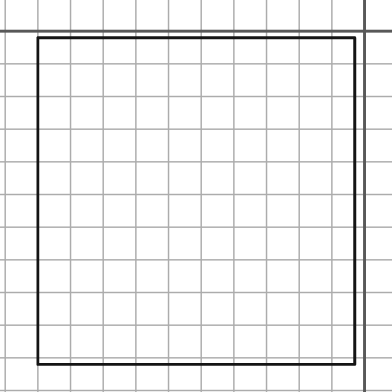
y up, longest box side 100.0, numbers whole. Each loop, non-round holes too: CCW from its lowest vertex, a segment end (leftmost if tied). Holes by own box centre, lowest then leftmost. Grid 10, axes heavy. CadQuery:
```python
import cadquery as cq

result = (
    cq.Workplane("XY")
    .moveTo(-100.0, -102.0)
    .lineTo(-3.0, -102.0)
    .lineTo(-3.0, -2.0)
    .lineTo(-100.0, -2.0)
    .close()
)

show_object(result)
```